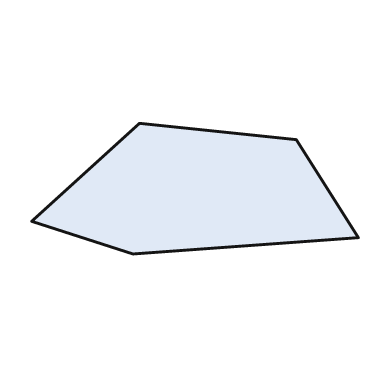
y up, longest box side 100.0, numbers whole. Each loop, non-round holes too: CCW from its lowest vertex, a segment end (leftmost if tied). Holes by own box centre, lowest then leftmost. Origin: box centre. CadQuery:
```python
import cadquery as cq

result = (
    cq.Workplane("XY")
    .moveTo(-19.0, -20.0)
    .lineTo(50.0, -15.0)
    .lineTo(31.0, 15.0)
    .lineTo(-17.0, 20.0)
    .lineTo(-50.0, -10.0)
    .close()
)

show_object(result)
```